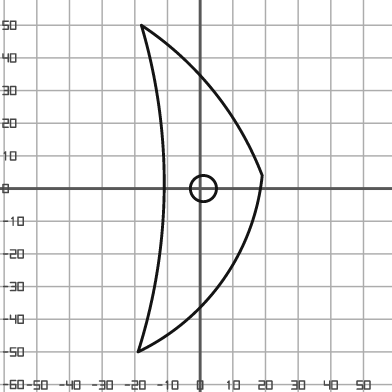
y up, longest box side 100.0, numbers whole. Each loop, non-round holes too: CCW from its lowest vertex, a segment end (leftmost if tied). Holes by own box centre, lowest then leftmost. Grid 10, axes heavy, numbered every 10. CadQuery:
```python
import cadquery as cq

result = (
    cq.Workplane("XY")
    .moveTo(-19.0, -50.0)
    .threePointArc((7.0, -28.0), (19.0, 4.0))
    .threePointArc((4.0, 30.0), (-18.0, 50.0))
    .threePointArc((-11.0, 0.0), (-19.0, -50.0))
    .close()
    .moveTo(1.0, 0.0)
    .circle(4.0)
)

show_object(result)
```